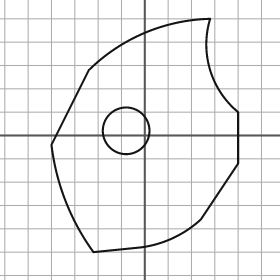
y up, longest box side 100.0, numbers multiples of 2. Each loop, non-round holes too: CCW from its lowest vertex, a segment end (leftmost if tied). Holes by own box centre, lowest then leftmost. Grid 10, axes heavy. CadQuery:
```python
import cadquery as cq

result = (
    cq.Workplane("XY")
    .moveTo(-22.0, -50.0)
    .lineTo(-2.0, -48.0)
    .threePointArc((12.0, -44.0), (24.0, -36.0))
    .lineTo(40.0, -12.0)
    .lineTo(40.0, 10.0)
    .threePointArc((28.0, 28.0), (28.0, 50.0))
    .threePointArc((0.0, 44.0), (-24.0, 28.0))
    .lineTo(-40.0, -4.0)
    .threePointArc((-34.0, -28.0), (-22.0, -50.0))
    .close()
    .moveTo(-8.0, 2.0)
    .circle(10.0)
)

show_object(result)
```